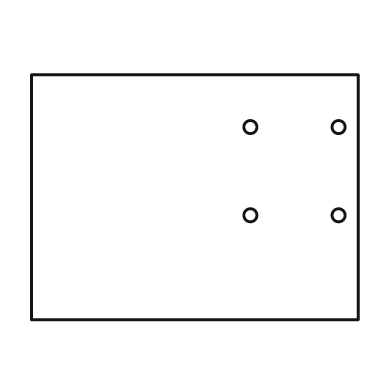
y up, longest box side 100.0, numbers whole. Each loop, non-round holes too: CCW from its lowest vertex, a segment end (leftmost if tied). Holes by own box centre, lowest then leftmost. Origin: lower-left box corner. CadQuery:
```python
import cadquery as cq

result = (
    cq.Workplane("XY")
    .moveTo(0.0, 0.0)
    .lineTo(100.0, 0.0)
    .lineTo(100.0, 75.0)
    .lineTo(0.0, 75.0)
    .close()
    .moveTo(67.0, 32.0)
    .circle(2.0)
    .moveTo(94.0, 32.0)
    .circle(2.0)
    .moveTo(67.0, 59.0)
    .circle(2.0)
    .moveTo(94.0, 59.0)
    .circle(2.0)
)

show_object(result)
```